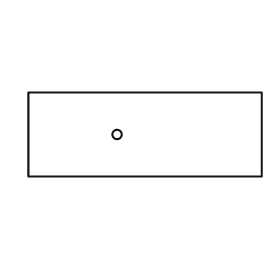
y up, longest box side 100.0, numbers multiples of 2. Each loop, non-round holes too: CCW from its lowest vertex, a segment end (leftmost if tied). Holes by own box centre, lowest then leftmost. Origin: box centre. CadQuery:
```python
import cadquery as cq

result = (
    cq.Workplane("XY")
    .moveTo(-50.0, -18.0)
    .lineTo(50.0, -18.0)
    .lineTo(50.0, 18.0)
    .lineTo(-50.0, 18.0)
    .close()
    .moveTo(-12.0, 0.0)
    .circle(2.0)
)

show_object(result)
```